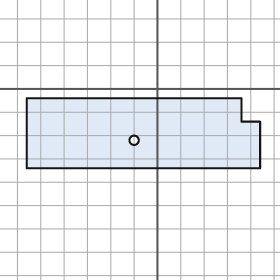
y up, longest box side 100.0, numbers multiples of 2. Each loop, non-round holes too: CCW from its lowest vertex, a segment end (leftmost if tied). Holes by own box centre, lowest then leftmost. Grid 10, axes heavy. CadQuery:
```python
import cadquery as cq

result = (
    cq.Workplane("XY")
    .moveTo(-56.0, -34.0)
    .lineTo(44.0, -34.0)
    .lineTo(44.0, -14.0)
    .lineTo(36.0, -14.0)
    .lineTo(36.0, -4.0)
    .lineTo(-56.0, -4.0)
    .close()
    .moveTo(-10.0, -22.0)
    .circle(2.0)
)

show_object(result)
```